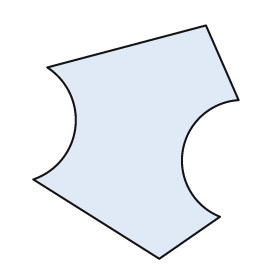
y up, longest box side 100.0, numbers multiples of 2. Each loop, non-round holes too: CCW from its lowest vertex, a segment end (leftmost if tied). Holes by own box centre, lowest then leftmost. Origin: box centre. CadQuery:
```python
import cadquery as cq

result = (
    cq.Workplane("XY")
    .moveTo(10.0, -50.0)
    .lineTo(36.0, -32.0)
    .threePointArc((20.0, -4.0), (44.0, 18.0))
    .lineTo(30.0, 50.0)
    .lineTo(-38.0, 32.0)
    .threePointArc((-26.0, 6.0), (-44.0, -16.0))
    .close()
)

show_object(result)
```